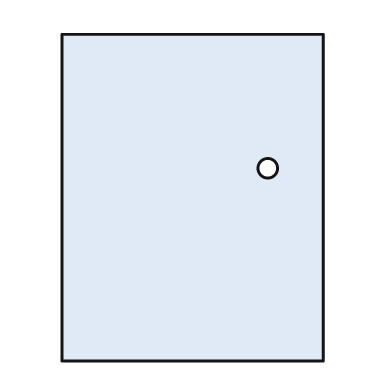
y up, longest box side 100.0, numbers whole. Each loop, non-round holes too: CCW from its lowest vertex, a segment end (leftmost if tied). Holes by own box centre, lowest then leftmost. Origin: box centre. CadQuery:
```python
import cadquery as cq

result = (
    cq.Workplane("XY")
    .moveTo(-40.0, -50.0)
    .lineTo(40.0, -50.0)
    .lineTo(40.0, 50.0)
    .lineTo(-40.0, 50.0)
    .close()
    .moveTo(23.0, 9.0)
    .circle(3.0)
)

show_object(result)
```